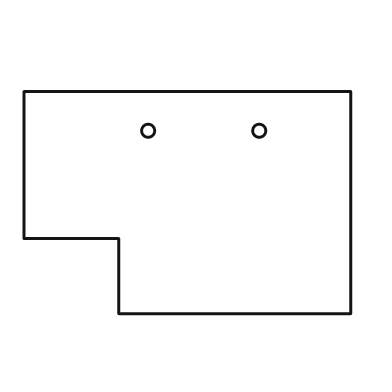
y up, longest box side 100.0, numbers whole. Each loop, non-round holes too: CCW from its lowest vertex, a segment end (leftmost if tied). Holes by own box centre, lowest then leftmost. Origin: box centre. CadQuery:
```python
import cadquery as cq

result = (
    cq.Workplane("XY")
    .moveTo(-21.0, -34.0)
    .lineTo(50.0, -34.0)
    .lineTo(50.0, 34.0)
    .lineTo(-50.0, 34.0)
    .lineTo(-50.0, -11.0)
    .lineTo(-21.0, -11.0)
    .close()
    .moveTo(-12.0, 22.0)
    .circle(2.0)
    .moveTo(22.0, 22.0)
    .circle(2.0)
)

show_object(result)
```